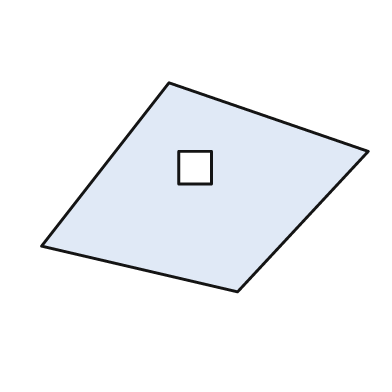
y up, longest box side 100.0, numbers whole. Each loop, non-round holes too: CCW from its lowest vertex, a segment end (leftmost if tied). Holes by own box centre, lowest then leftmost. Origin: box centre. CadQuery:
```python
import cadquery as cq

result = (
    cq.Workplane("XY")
    .moveTo(10.0, -32.0)
    .lineTo(50.0, 11.0)
    .lineTo(-11.0, 32.0)
    .lineTo(-50.0, -18.0)
    .close()
    .moveTo(-8.0, 1.0)
    .lineTo(2.0, 1.0)
    .lineTo(2.0, 11.0)
    .lineTo(-8.0, 11.0)
    .close()
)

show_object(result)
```